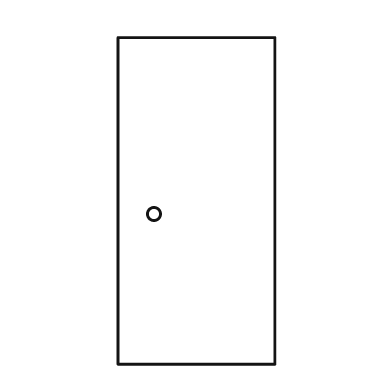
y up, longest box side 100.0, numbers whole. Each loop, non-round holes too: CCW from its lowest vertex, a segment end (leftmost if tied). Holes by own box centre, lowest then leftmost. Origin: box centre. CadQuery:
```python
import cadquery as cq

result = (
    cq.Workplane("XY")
    .moveTo(-24.0, -50.0)
    .lineTo(24.0, -50.0)
    .lineTo(24.0, 50.0)
    .lineTo(-24.0, 50.0)
    .close()
    .moveTo(-13.0, -4.0)
    .circle(2.0)
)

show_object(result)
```